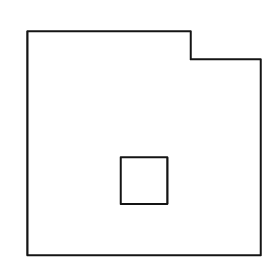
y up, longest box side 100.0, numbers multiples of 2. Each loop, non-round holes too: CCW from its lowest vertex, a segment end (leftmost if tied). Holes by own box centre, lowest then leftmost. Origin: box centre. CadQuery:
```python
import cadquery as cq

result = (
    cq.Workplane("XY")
    .moveTo(-50.0, -48.0)
    .lineTo(50.0, -48.0)
    .lineTo(50.0, 36.0)
    .lineTo(20.0, 36.0)
    .lineTo(20.0, 48.0)
    .lineTo(-50.0, 48.0)
    .close()
    .moveTo(-10.0, -26.0)
    .lineTo(10.0, -26.0)
    .lineTo(10.0, -6.0)
    .lineTo(-10.0, -6.0)
    .close()
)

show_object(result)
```